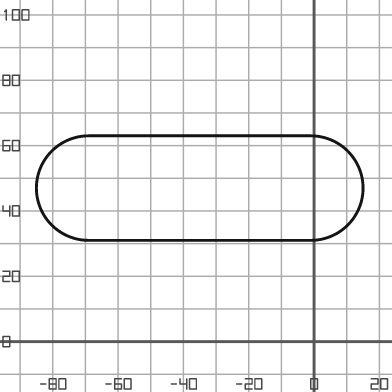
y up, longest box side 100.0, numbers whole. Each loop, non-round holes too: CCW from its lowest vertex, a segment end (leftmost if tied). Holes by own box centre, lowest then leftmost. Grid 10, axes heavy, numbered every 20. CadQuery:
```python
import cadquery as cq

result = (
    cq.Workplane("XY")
    .moveTo(-69.0, 31.0)
    .lineTo(-1.0, 31.0)
    .threePointArc((15.0, 47.0), (-1.0, 63.0))
    .lineTo(-69.0, 63.0)
    .threePointArc((-85.0, 47.0), (-69.0, 31.0))
    .close()
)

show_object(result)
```